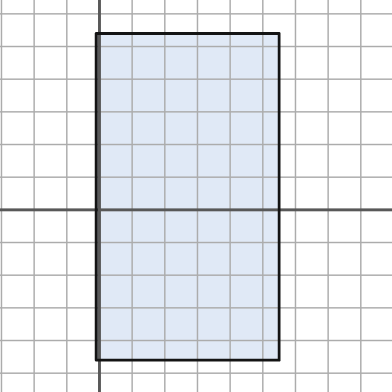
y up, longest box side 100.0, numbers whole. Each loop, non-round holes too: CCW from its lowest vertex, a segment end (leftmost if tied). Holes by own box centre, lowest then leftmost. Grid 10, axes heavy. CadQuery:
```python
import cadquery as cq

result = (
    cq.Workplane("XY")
    .moveTo(-1.0, -46.0)
    .lineTo(55.0, -46.0)
    .lineTo(55.0, 54.0)
    .lineTo(-1.0, 54.0)
    .close()
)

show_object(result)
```